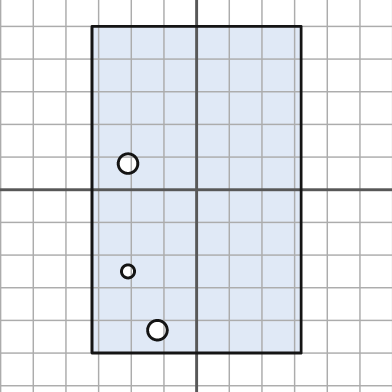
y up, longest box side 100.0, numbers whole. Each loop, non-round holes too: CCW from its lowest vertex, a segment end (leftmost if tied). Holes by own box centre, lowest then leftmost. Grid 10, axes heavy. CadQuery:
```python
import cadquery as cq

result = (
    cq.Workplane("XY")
    .moveTo(-32.0, -50.0)
    .lineTo(32.0, -50.0)
    .lineTo(32.0, 50.0)
    .lineTo(-32.0, 50.0)
    .close()
    .moveTo(-12.0, -43.0)
    .circle(3.0)
    .moveTo(-21.0, -25.0)
    .circle(2.0)
    .moveTo(-21.0, 8.0)
    .circle(3.0)
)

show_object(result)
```